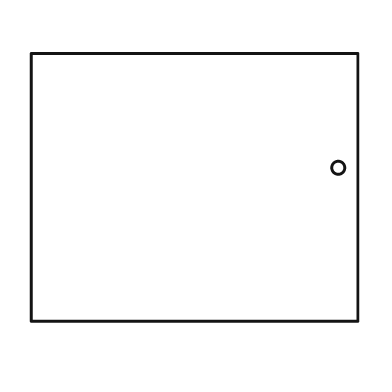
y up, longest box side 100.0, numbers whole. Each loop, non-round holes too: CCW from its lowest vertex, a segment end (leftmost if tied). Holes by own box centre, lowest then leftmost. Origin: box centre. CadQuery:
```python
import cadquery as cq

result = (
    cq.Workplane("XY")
    .moveTo(-50.0, -41.0)
    .lineTo(50.0, -41.0)
    .lineTo(50.0, 41.0)
    .lineTo(-50.0, 41.0)
    .close()
    .moveTo(44.0, 6.0)
    .circle(2.0)
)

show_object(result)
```